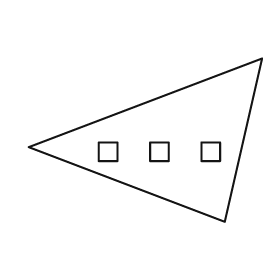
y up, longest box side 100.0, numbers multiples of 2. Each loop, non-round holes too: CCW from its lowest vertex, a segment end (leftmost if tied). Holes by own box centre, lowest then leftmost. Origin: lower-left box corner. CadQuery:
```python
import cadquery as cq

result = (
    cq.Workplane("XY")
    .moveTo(84.0, 0.0)
    .lineTo(100.0, 70.0)
    .lineTo(0.0, 32.0)
    .close()
    .moveTo(30.0, 26.0)
    .lineTo(38.0, 26.0)
    .lineTo(38.0, 34.0)
    .lineTo(30.0, 34.0)
    .close()
    .moveTo(52.0, 26.0)
    .lineTo(60.0, 26.0)
    .lineTo(60.0, 34.0)
    .lineTo(52.0, 34.0)
    .close()
    .moveTo(74.0, 26.0)
    .lineTo(82.0, 26.0)
    .lineTo(82.0, 34.0)
    .lineTo(74.0, 34.0)
    .close()
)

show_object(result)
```